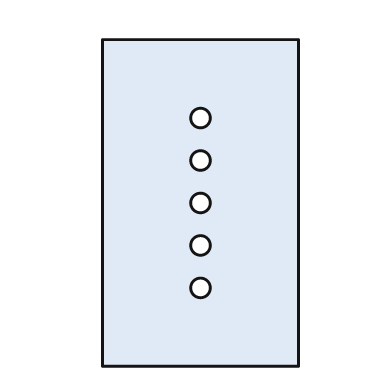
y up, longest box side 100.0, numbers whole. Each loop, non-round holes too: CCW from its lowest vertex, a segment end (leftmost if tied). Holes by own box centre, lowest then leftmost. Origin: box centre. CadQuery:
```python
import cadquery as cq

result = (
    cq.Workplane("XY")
    .moveTo(-30.0, -50.0)
    .lineTo(30.0, -50.0)
    .lineTo(30.0, 50.0)
    .lineTo(-30.0, 50.0)
    .close()
    .moveTo(0.0, -26.0)
    .circle(3.0)
    .moveTo(0.0, -13.0)
    .circle(3.0)
    .moveTo(0.0, 0.0)
    .circle(3.0)
    .moveTo(0.0, 13.0)
    .circle(3.0)
    .moveTo(0.0, 26.0)
    .circle(3.0)
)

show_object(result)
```